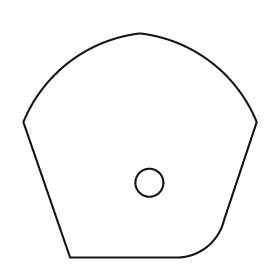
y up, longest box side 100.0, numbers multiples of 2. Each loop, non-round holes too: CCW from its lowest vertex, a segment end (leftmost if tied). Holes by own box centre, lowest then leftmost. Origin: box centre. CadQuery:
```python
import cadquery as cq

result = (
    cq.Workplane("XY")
    .moveTo(-30.0, -48.0)
    .lineTo(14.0, -48.0)
    .threePointArc((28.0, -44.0), (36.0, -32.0))
    .lineTo(50.0, 10.0)
    .threePointArc((30.0, 36.0), (0.0, 48.0))
    .threePointArc((-30.0, 36.0), (-50.0, 10.0))
    .close()
    .moveTo(4.0, -16.0)
    .circle(6.0)
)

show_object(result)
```